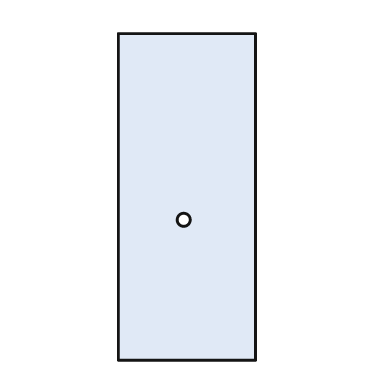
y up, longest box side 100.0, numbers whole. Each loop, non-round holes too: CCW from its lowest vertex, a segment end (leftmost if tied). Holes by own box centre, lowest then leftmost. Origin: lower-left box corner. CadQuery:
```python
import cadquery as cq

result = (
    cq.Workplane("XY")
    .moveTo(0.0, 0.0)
    .lineTo(42.0, 0.0)
    .lineTo(42.0, 100.0)
    .lineTo(0.0, 100.0)
    .close()
    .moveTo(20.0, 43.0)
    .circle(2.0)
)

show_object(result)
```